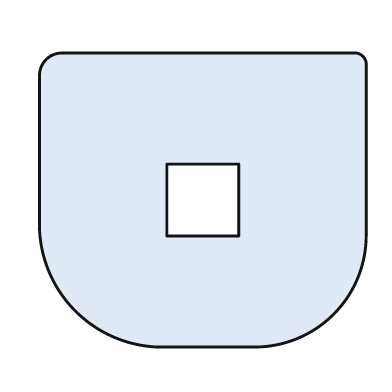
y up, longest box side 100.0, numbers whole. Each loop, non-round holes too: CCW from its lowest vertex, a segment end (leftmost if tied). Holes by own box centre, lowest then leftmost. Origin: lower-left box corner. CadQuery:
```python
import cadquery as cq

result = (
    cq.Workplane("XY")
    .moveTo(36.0, 0.0)
    .lineTo(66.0, 0.0)
    .threePointArc((90.0, 10.0), (100.0, 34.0))
    .lineTo(100.0, 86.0)
    .threePointArc((99.0, 89.0), (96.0, 90.0))
    .lineTo(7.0, 90.0)
    .threePointArc((2.0, 88.0), (0.0, 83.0))
    .lineTo(0.0, 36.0)
    .threePointArc((11.0, 11.0), (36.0, 0.0))
    .close()
    .moveTo(39.0, 34.0)
    .lineTo(61.0, 34.0)
    .lineTo(61.0, 56.0)
    .lineTo(39.0, 56.0)
    .close()
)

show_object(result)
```